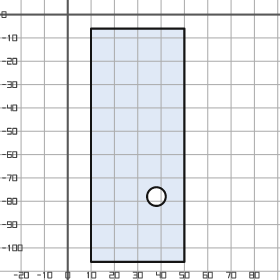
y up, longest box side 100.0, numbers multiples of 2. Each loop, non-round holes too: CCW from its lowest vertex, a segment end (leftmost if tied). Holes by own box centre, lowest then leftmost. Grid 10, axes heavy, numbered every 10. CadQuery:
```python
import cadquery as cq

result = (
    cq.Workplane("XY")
    .moveTo(10.0, -106.0)
    .lineTo(50.0, -106.0)
    .lineTo(50.0, -6.0)
    .lineTo(10.0, -6.0)
    .close()
    .moveTo(38.0, -78.0)
    .circle(4.0)
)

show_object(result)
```